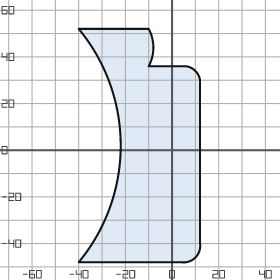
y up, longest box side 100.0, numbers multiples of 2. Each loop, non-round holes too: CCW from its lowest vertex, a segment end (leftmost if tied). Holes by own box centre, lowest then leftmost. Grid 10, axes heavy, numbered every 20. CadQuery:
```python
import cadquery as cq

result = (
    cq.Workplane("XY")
    .moveTo(-40.0, -48.0)
    .lineTo(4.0, -48.0)
    .threePointArc((10.0, -46.0), (12.0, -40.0))
    .lineTo(12.0, 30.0)
    .threePointArc((10.0, 34.0), (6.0, 36.0))
    .lineTo(-10.0, 36.0)
    .threePointArc((-8.0, 44.0), (-10.0, 52.0))
    .lineTo(-40.0, 52.0)
    .threePointArc((-22.0, 2.0), (-40.0, -48.0))
    .close()
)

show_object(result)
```